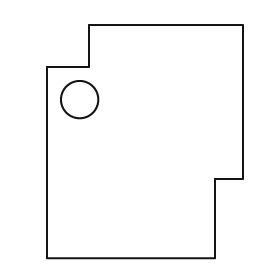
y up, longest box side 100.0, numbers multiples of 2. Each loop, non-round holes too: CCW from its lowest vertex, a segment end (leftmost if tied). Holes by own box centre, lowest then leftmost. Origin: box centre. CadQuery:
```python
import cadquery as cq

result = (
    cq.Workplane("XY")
    .moveTo(-42.0, -50.0)
    .lineTo(30.0, -50.0)
    .lineTo(30.0, -16.0)
    .lineTo(42.0, -16.0)
    .lineTo(42.0, 50.0)
    .lineTo(-24.0, 50.0)
    .lineTo(-24.0, 32.0)
    .lineTo(-42.0, 32.0)
    .close()
    .moveTo(-28.0, 18.0)
    .circle(8.0)
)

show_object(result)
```